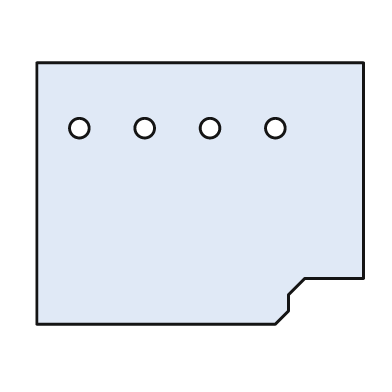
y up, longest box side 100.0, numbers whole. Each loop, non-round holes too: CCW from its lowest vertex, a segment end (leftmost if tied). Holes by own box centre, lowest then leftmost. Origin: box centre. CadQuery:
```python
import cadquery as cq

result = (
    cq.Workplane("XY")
    .moveTo(-50.0, -40.0)
    .lineTo(23.0, -40.0)
    .lineTo(27.0, -36.0)
    .lineTo(27.0, -31.0)
    .lineTo(32.0, -26.0)
    .lineTo(50.0, -26.0)
    .lineTo(50.0, 40.0)
    .lineTo(-50.0, 40.0)
    .close()
    .moveTo(-37.0, 20.0)
    .circle(3.0)
    .moveTo(-17.0, 20.0)
    .circle(3.0)
    .moveTo(3.0, 20.0)
    .circle(3.0)
    .moveTo(23.0, 20.0)
    .circle(3.0)
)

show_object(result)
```